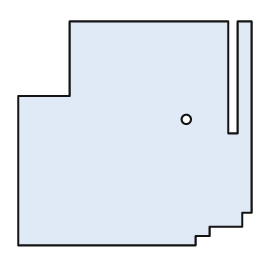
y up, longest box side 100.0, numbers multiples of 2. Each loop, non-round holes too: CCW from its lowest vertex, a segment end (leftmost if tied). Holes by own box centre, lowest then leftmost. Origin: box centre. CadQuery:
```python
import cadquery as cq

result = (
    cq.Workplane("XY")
    .moveTo(-50.0, -48.0)
    .lineTo(26.0, -48.0)
    .lineTo(26.0, -44.0)
    .lineTo(32.0, -44.0)
    .lineTo(32.0, -40.0)
    .lineTo(46.0, -40.0)
    .lineTo(46.0, -34.0)
    .lineTo(50.0, -34.0)
    .lineTo(50.0, 48.0)
    .lineTo(44.0, 48.0)
    .lineTo(44.0, 0.0)
    .lineTo(40.0, 0.0)
    .lineTo(40.0, 48.0)
    .lineTo(-28.0, 48.0)
    .lineTo(-28.0, 16.0)
    .lineTo(-50.0, 16.0)
    .close()
    .moveTo(22.0, 6.0)
    .circle(2.0)
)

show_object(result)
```